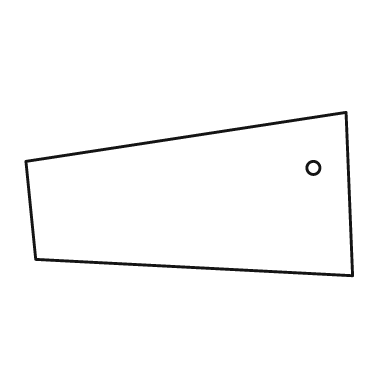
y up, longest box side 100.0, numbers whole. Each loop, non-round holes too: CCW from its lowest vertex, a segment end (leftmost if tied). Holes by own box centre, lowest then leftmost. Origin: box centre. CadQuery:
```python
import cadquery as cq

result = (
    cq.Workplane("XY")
    .moveTo(50.0, -25.0)
    .lineTo(48.0, 25.0)
    .lineTo(-50.0, 10.0)
    .lineTo(-47.0, -20.0)
    .close()
    .moveTo(38.0, 8.0)
    .circle(2.0)
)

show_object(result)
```